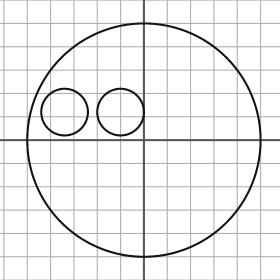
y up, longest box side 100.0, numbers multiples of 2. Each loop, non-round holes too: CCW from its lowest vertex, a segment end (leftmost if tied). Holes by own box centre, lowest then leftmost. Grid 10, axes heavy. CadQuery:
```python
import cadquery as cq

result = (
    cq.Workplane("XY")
    .moveTo(0.0, 0.0)
    .circle(50.0)
    .moveTo(-34.0, 12.0)
    .circle(10.0)
    .moveTo(-10.0, 12.0)
    .circle(10.0)
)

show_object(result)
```